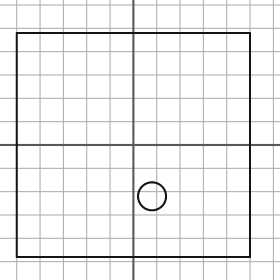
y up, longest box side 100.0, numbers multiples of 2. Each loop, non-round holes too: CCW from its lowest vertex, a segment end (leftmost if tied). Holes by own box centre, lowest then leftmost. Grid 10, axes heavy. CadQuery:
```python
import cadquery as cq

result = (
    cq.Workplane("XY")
    .moveTo(-50.0, -48.0)
    .lineTo(50.0, -48.0)
    .lineTo(50.0, 48.0)
    .lineTo(-50.0, 48.0)
    .close()
    .moveTo(8.0, -22.0)
    .circle(6.0)
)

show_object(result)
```